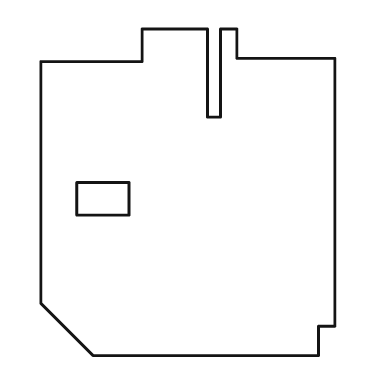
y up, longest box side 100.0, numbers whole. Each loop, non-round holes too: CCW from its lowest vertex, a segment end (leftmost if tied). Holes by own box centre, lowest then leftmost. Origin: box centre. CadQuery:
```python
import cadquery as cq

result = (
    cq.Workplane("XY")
    .moveTo(-29.0, -50.0)
    .lineTo(40.0, -50.0)
    .lineTo(40.0, -41.0)
    .lineTo(45.0, -41.0)
    .lineTo(45.0, 41.0)
    .lineTo(15.0, 41.0)
    .lineTo(15.0, 50.0)
    .lineTo(10.0, 50.0)
    .lineTo(10.0, 23.0)
    .lineTo(6.0, 23.0)
    .lineTo(6.0, 50.0)
    .lineTo(-14.0, 50.0)
    .lineTo(-14.0, 40.0)
    .lineTo(-45.0, 40.0)
    .lineTo(-45.0, -34.0)
    .close()
    .moveTo(-34.0, -7.0)
    .lineTo(-18.0, -7.0)
    .lineTo(-18.0, 3.0)
    .lineTo(-34.0, 3.0)
    .close()
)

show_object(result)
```